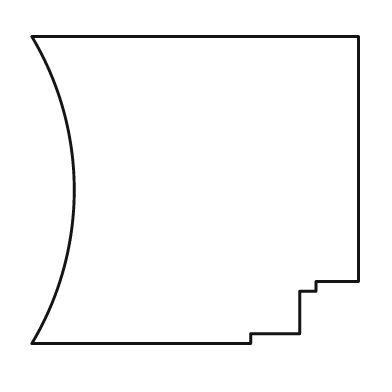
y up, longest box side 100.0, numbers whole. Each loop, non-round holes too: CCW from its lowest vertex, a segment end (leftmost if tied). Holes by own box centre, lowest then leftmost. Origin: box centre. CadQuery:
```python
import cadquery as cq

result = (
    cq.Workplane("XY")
    .moveTo(-50.0, -47.0)
    .lineTo(17.0, -47.0)
    .lineTo(17.0, -44.0)
    .lineTo(32.0, -44.0)
    .lineTo(32.0, -31.0)
    .lineTo(37.0, -31.0)
    .lineTo(37.0, -28.0)
    .lineTo(50.0, -28.0)
    .lineTo(50.0, 47.0)
    .lineTo(-50.0, 47.0)
    .threePointArc((-37.0, 0.0), (-50.0, -47.0))
    .close()
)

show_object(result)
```